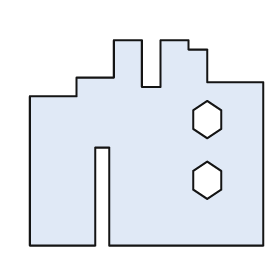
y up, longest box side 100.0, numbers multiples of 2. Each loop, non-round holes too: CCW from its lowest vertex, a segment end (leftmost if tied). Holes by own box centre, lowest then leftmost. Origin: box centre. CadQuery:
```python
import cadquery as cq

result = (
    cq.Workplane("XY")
    .moveTo(-50.0, -44.0)
    .lineTo(-22.0, -44.0)
    .lineTo(-22.0, -2.0)
    .lineTo(-16.0, -2.0)
    .lineTo(-16.0, -44.0)
    .lineTo(50.0, -44.0)
    .lineTo(50.0, 26.0)
    .lineTo(26.0, 26.0)
    .lineTo(26.0, 40.0)
    .lineTo(18.0, 40.0)
    .lineTo(18.0, 44.0)
    .lineTo(6.0, 44.0)
    .lineTo(6.0, 24.0)
    .lineTo(-2.0, 24.0)
    .lineTo(-2.0, 44.0)
    .lineTo(-14.0, 44.0)
    .lineTo(-14.0, 28.0)
    .lineTo(-30.0, 28.0)
    .lineTo(-30.0, 20.0)
    .lineTo(-50.0, 20.0)
    .close()
    .moveTo(26.0, -24.0)
    .lineTo(32.0, -20.0)
    .lineTo(32.0, -12.0)
    .lineTo(26.0, -8.0)
    .lineTo(20.0, -12.0)
    .lineTo(20.0, -20.0)
    .close()
    .moveTo(26.0, 2.0)
    .lineTo(32.0, 6.0)
    .lineTo(32.0, 14.0)
    .lineTo(26.0, 18.0)
    .lineTo(20.0, 14.0)
    .lineTo(20.0, 6.0)
    .close()
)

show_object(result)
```